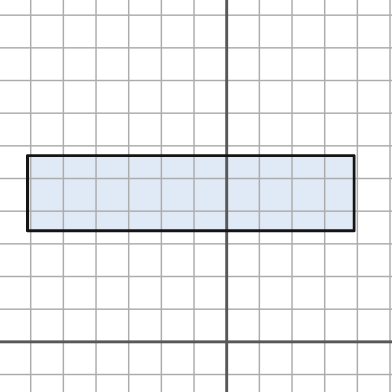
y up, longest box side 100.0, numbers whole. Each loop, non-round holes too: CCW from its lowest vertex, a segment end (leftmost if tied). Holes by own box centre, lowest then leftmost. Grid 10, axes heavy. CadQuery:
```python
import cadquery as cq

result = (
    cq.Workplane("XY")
    .moveTo(-61.0, 34.0)
    .lineTo(39.0, 34.0)
    .lineTo(39.0, 57.0)
    .lineTo(-61.0, 57.0)
    .close()
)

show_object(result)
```